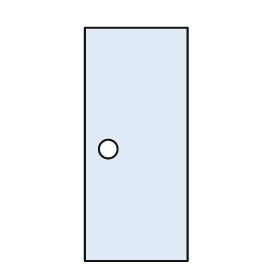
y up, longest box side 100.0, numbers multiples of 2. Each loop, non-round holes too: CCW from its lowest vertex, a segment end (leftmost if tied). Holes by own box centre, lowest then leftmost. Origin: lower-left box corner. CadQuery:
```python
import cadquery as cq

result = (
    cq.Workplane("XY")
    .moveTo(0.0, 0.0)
    .lineTo(44.0, 0.0)
    .lineTo(44.0, 100.0)
    .lineTo(0.0, 100.0)
    .close()
    .moveTo(10.0, 48.0)
    .circle(4.0)
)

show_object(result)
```